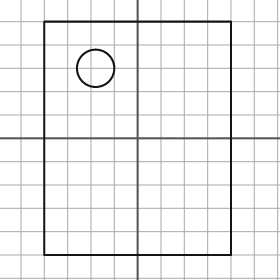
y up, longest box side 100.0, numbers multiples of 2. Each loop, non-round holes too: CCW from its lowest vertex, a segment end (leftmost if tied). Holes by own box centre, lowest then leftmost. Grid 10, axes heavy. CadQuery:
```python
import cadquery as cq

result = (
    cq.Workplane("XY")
    .moveTo(-40.0, -50.0)
    .lineTo(40.0, -50.0)
    .lineTo(40.0, 50.0)
    .lineTo(-40.0, 50.0)
    .close()
    .moveTo(-18.0, 30.0)
    .circle(8.0)
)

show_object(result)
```